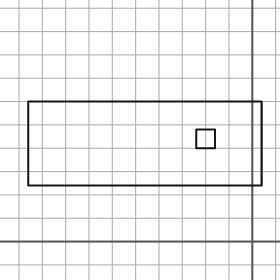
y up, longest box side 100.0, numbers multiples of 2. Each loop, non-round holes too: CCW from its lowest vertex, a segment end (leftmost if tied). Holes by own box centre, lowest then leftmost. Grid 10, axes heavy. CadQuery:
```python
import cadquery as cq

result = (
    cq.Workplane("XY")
    .moveTo(-96.0, 24.0)
    .lineTo(4.0, 24.0)
    .lineTo(4.0, 60.0)
    .lineTo(-96.0, 60.0)
    .close()
    .moveTo(-24.0, 40.0)
    .lineTo(-16.0, 40.0)
    .lineTo(-16.0, 48.0)
    .lineTo(-24.0, 48.0)
    .close()
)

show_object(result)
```